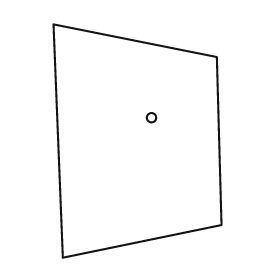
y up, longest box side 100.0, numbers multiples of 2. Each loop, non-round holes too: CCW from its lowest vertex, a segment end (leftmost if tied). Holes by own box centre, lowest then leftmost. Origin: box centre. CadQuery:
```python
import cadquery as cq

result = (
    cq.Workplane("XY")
    .moveTo(-32.0, -50.0)
    .lineTo(36.0, -36.0)
    .lineTo(34.0, 36.0)
    .lineTo(-36.0, 50.0)
    .close()
    .moveTo(6.0, 10.0)
    .circle(2.0)
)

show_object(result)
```